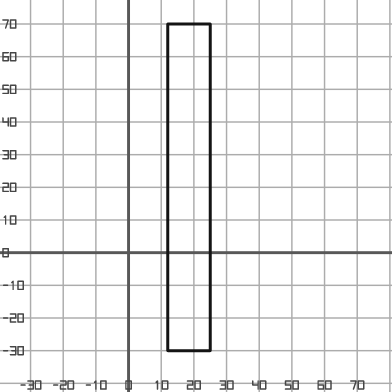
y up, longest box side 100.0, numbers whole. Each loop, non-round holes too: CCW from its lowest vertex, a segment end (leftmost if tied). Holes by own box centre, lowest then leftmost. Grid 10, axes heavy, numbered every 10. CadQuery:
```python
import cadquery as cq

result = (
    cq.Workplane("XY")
    .moveTo(12.0, -30.0)
    .lineTo(25.0, -30.0)
    .lineTo(25.0, 70.0)
    .lineTo(12.0, 70.0)
    .close()
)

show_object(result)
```